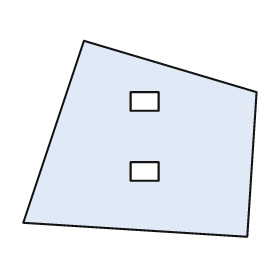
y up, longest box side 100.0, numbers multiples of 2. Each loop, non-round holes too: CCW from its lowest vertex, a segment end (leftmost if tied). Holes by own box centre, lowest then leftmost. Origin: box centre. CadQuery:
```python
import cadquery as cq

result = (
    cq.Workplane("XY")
    .moveTo(46.0, -42.0)
    .lineTo(50.0, 20.0)
    .lineTo(-24.0, 42.0)
    .lineTo(-50.0, -36.0)
    .close()
    .moveTo(-4.0, -18.0)
    .lineTo(8.0, -18.0)
    .lineTo(8.0, -10.0)
    .lineTo(-4.0, -10.0)
    .close()
    .moveTo(-4.0, 12.0)
    .lineTo(8.0, 12.0)
    .lineTo(8.0, 20.0)
    .lineTo(-4.0, 20.0)
    .close()
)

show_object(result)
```